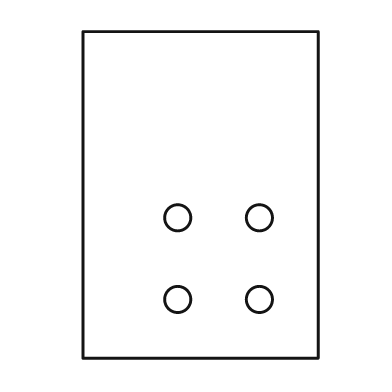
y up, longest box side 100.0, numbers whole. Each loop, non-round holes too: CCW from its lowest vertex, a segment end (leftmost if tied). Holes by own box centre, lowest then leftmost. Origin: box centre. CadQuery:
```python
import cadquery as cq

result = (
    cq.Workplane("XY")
    .moveTo(-36.0, -50.0)
    .lineTo(36.0, -50.0)
    .lineTo(36.0, 50.0)
    .lineTo(-36.0, 50.0)
    .close()
    .moveTo(-7.0, -32.0)
    .circle(4.0)
    .moveTo(18.0, -32.0)
    .circle(4.0)
    .moveTo(-7.0, -7.0)
    .circle(4.0)
    .moveTo(18.0, -7.0)
    .circle(4.0)
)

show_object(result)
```